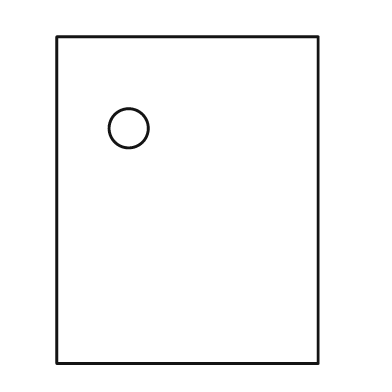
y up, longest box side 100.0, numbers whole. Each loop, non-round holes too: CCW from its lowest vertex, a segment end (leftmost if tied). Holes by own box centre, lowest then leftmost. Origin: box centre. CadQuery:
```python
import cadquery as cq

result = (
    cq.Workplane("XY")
    .moveTo(-40.0, -50.0)
    .lineTo(40.0, -50.0)
    .lineTo(40.0, 50.0)
    .lineTo(-40.0, 50.0)
    .close()
    .moveTo(-18.0, 22.0)
    .circle(6.0)
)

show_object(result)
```